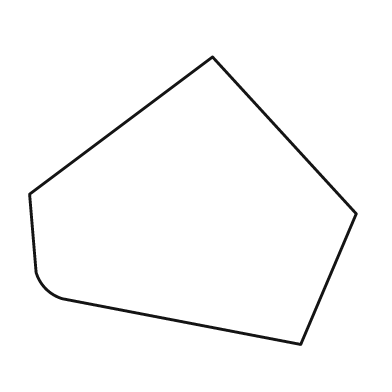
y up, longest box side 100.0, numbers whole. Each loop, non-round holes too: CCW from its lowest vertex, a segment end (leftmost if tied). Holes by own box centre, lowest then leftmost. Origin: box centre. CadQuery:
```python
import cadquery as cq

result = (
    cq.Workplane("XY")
    .moveTo(33.0, -44.0)
    .lineTo(50.0, -4.0)
    .lineTo(6.0, 44.0)
    .lineTo(-50.0, 2.0)
    .lineTo(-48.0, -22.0)
    .threePointArc((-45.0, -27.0), (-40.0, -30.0))
    .close()
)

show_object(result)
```